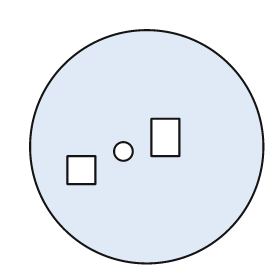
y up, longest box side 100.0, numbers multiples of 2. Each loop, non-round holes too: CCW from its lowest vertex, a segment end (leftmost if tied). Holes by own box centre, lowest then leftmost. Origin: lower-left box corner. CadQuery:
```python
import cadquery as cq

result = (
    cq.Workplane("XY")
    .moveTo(50.0, 50.0)
    .circle(50.0)
    .moveTo(16.0, 34.0)
    .lineTo(28.0, 34.0)
    .lineTo(28.0, 46.0)
    .lineTo(16.0, 46.0)
    .close()
    .moveTo(40.0, 48.0)
    .circle(4.0)
    .moveTo(52.0, 46.0)
    .lineTo(64.0, 46.0)
    .lineTo(64.0, 62.0)
    .lineTo(52.0, 62.0)
    .close()
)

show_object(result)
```